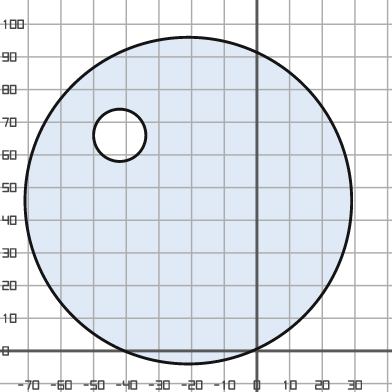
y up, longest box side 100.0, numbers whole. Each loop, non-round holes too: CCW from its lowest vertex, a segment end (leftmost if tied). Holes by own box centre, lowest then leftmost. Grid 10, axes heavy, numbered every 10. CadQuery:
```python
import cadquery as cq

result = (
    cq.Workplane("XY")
    .moveTo(-21.0, 46.0)
    .circle(50.0)
    .moveTo(-42.0, 66.0)
    .circle(8.0)
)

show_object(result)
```